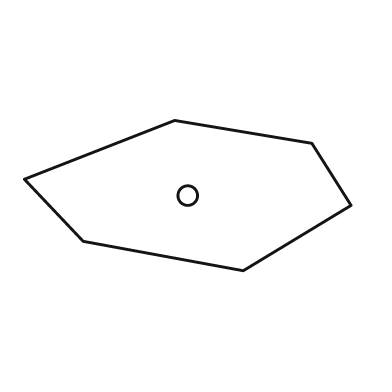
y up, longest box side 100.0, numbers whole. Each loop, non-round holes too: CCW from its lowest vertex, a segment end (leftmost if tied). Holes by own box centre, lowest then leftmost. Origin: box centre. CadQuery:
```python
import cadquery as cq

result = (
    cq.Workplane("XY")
    .moveTo(17.0, -23.0)
    .lineTo(50.0, -3.0)
    .lineTo(38.0, 16.0)
    .lineTo(-4.0, 23.0)
    .lineTo(-50.0, 5.0)
    .lineTo(-32.0, -14.0)
    .close()
    .moveTo(0.0, 0.0)
    .circle(3.0)
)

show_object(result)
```